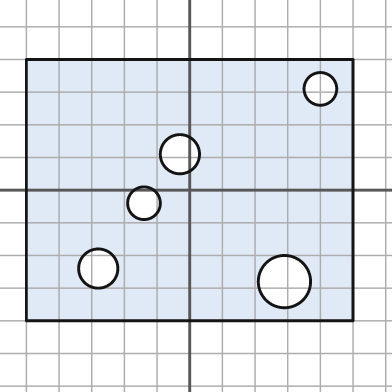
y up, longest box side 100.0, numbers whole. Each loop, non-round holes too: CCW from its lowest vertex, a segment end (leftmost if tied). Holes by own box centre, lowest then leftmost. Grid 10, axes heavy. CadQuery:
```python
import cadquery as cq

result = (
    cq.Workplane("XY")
    .moveTo(-50.0, -40.0)
    .lineTo(50.0, -40.0)
    .lineTo(50.0, 40.0)
    .lineTo(-50.0, 40.0)
    .close()
    .moveTo(29.0, -28.0)
    .circle(8.0)
    .moveTo(-28.0, -24.0)
    .circle(6.0)
    .moveTo(-14.0, -4.0)
    .circle(5.0)
    .moveTo(-3.0, 11.0)
    .circle(6.0)
    .moveTo(40.0, 31.0)
    .circle(5.0)
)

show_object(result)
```